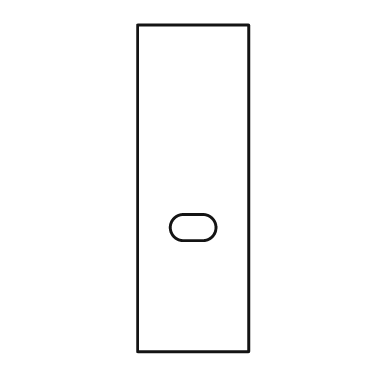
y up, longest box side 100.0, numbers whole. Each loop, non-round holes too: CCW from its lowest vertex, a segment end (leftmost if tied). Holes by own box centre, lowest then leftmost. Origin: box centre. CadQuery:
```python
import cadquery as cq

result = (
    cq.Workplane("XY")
    .moveTo(-17.0, -50.0)
    .lineTo(17.0, -50.0)
    .lineTo(17.0, 50.0)
    .lineTo(-17.0, 50.0)
    .close()
    .moveTo(-3.0, -16.0)
    .lineTo(3.0, -16.0)
    .threePointArc((7.0, -12.0), (3.0, -8.0))
    .lineTo(-3.0, -8.0)
    .threePointArc((-7.0, -12.0), (-3.0, -16.0))
    .close()
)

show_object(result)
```